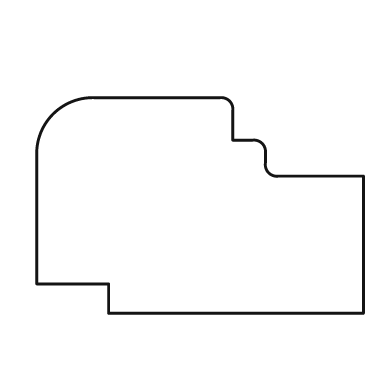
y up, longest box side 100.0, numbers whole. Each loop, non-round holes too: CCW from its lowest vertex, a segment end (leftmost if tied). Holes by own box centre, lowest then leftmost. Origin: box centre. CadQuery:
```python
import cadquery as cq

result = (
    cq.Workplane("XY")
    .moveTo(-28.0, -33.0)
    .lineTo(50.0, -33.0)
    .lineTo(50.0, 9.0)
    .lineTo(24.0, 9.0)
    .threePointArc((21.0, 10.0), (20.0, 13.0))
    .lineTo(20.0, 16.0)
    .threePointArc((19.0, 19.0), (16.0, 20.0))
    .lineTo(10.0, 20.0)
    .lineTo(10.0, 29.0)
    .threePointArc((9.0, 32.0), (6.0, 33.0))
    .lineTo(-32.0, 33.0)
    .threePointArc((-45.0, 28.0), (-50.0, 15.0))
    .lineTo(-50.0, -24.0)
    .lineTo(-28.0, -24.0)
    .close()
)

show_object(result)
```